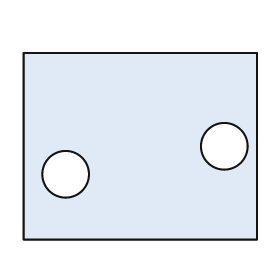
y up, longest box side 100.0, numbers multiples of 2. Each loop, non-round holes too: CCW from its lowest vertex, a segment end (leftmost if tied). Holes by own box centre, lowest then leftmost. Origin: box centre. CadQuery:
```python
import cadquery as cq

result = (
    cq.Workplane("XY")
    .moveTo(-50.0, -40.0)
    .lineTo(50.0, -40.0)
    .lineTo(50.0, 40.0)
    .lineTo(-50.0, 40.0)
    .close()
    .moveTo(-32.0, -12.0)
    .circle(10.0)
    .moveTo(36.0, 0.0)
    .circle(10.0)
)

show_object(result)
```